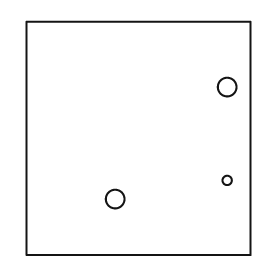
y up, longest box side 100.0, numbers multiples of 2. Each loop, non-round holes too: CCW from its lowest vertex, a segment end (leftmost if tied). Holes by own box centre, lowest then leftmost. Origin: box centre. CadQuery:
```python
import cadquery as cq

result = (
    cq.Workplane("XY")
    .moveTo(-48.0, -50.0)
    .lineTo(48.0, -50.0)
    .lineTo(48.0, 50.0)
    .lineTo(-48.0, 50.0)
    .close()
    .moveTo(-10.0, -26.0)
    .circle(4.0)
    .moveTo(38.0, -18.0)
    .circle(2.0)
    .moveTo(38.0, 22.0)
    .circle(4.0)
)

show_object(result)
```